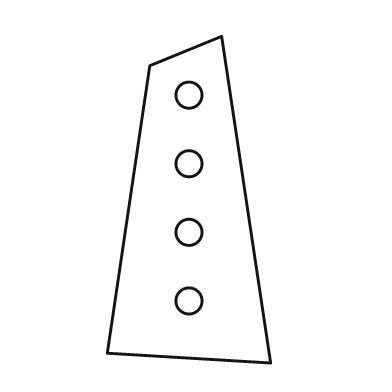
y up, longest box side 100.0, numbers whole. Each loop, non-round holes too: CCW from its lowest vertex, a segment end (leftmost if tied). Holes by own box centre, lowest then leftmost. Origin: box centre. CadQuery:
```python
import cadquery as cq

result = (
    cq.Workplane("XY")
    .moveTo(25.0, -50.0)
    .lineTo(10.0, 50.0)
    .lineTo(-12.0, 41.0)
    .lineTo(-25.0, -47.0)
    .close()
    .moveTo(0.0, -31.0)
    .circle(4.0)
    .moveTo(0.0, -10.0)
    .circle(4.0)
    .moveTo(0.0, 11.0)
    .circle(4.0)
    .moveTo(0.0, 32.0)
    .circle(4.0)
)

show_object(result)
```